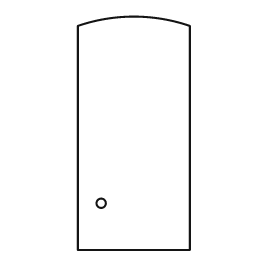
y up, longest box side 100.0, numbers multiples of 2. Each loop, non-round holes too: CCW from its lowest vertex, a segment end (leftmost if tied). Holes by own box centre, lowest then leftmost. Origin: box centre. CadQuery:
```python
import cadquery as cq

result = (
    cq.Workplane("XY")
    .moveTo(-24.0, -50.0)
    .lineTo(24.0, -50.0)
    .lineTo(24.0, 46.0)
    .threePointArc((0.0, 50.0), (-24.0, 46.0))
    .close()
    .moveTo(-14.0, -30.0)
    .circle(2.0)
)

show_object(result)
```